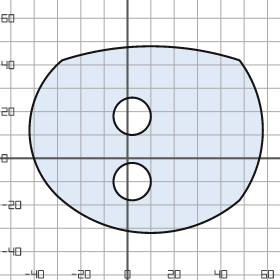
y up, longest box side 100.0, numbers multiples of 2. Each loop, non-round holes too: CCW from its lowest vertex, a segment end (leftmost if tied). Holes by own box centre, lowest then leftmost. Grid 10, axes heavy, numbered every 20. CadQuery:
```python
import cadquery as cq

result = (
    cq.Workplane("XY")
    .moveTo(-28.0, -18.0)
    .threePointArc((10.0, -32.0), (48.0, -18.0))
    .threePointArc((58.0, 12.0), (48.0, 42.0))
    .threePointArc((10.0, 48.0), (-28.0, 42.0))
    .threePointArc((-42.0, 12.0), (-28.0, -18.0))
    .close()
    .moveTo(2.0, -10.0)
    .circle(8.0)
    .moveTo(2.0, 18.0)
    .circle(8.0)
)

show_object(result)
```